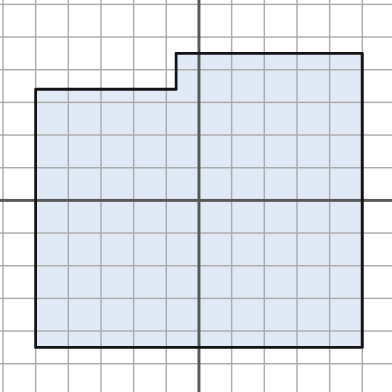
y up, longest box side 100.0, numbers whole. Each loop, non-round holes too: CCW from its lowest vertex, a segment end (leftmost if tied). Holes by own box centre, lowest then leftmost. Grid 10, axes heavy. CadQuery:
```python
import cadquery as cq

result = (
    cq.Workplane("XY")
    .moveTo(-50.0, -45.0)
    .lineTo(50.0, -45.0)
    .lineTo(50.0, 45.0)
    .lineTo(-7.0, 45.0)
    .lineTo(-7.0, 34.0)
    .lineTo(-50.0, 34.0)
    .close()
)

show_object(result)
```